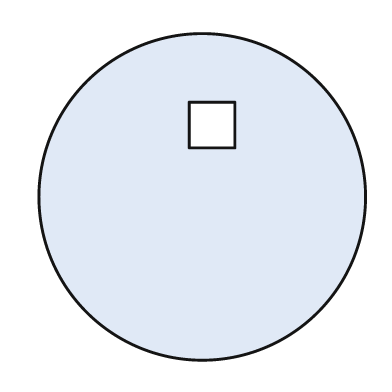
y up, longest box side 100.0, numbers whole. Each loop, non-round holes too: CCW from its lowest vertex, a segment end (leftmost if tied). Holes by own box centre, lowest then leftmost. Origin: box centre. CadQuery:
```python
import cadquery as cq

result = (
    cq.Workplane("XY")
    .moveTo(0.0, 0.0)
    .circle(50.0)
    .moveTo(-4.0, 15.0)
    .lineTo(10.0, 15.0)
    .lineTo(10.0, 29.0)
    .lineTo(-4.0, 29.0)
    .close()
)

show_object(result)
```